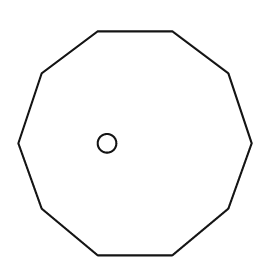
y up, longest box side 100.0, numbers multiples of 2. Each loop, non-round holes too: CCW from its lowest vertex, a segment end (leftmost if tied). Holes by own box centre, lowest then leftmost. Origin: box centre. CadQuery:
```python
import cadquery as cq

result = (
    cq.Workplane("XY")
    .moveTo(-16.0, -48.0)
    .lineTo(16.0, -48.0)
    .lineTo(40.0, -28.0)
    .lineTo(50.0, 0.0)
    .lineTo(40.0, 30.0)
    .lineTo(16.0, 48.0)
    .lineTo(-16.0, 48.0)
    .lineTo(-40.0, 30.0)
    .lineTo(-50.0, 0.0)
    .lineTo(-40.0, -28.0)
    .close()
    .moveTo(-12.0, 0.0)
    .circle(4.0)
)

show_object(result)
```